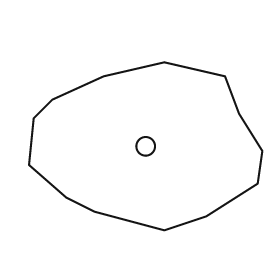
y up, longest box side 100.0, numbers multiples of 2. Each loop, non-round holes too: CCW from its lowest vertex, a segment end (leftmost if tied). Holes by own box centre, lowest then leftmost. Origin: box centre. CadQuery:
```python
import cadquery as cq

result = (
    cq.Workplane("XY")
    .moveTo(8.0, -36.0)
    .lineTo(26.0, -30.0)
    .lineTo(48.0, -16.0)
    .lineTo(50.0, -2.0)
    .lineTo(40.0, 14.0)
    .lineTo(34.0, 30.0)
    .lineTo(8.0, 36.0)
    .lineTo(-18.0, 30.0)
    .lineTo(-40.0, 20.0)
    .lineTo(-48.0, 12.0)
    .lineTo(-50.0, -8.0)
    .lineTo(-34.0, -22.0)
    .lineTo(-22.0, -28.0)
    .close()
    .moveTo(0.0, 0.0)
    .circle(4.0)
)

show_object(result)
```